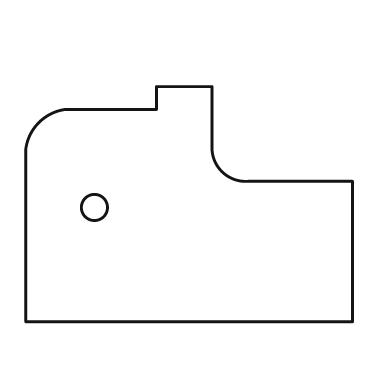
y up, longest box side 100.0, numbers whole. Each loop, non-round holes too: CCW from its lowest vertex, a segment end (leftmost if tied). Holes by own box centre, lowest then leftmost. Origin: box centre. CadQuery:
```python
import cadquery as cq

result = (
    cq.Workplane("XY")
    .moveTo(-50.0, -36.0)
    .lineTo(50.0, -36.0)
    .lineTo(50.0, 7.0)
    .lineTo(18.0, 7.0)
    .threePointArc((10.0, 10.0), (7.0, 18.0))
    .lineTo(7.0, 36.0)
    .lineTo(-10.0, 36.0)
    .lineTo(-10.0, 29.0)
    .lineTo(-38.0, 29.0)
    .threePointArc((-46.0, 25.0), (-50.0, 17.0))
    .close()
    .moveTo(-29.0, -1.0)
    .circle(4.0)
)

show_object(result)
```